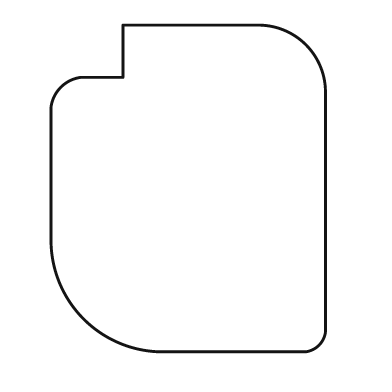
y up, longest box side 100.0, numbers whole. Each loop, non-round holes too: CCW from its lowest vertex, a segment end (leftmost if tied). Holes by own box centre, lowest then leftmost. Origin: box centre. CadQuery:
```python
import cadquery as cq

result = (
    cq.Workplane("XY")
    .moveTo(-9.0, -50.0)
    .lineTo(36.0, -50.0)
    .threePointArc((40.0, -48.0), (42.0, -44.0))
    .lineTo(42.0, 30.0)
    .threePointArc((36.0, 44.0), (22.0, 50.0))
    .lineTo(-20.0, 50.0)
    .lineTo(-20.0, 34.0)
    .lineTo(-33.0, 34.0)
    .threePointArc((-39.0, 31.0), (-42.0, 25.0))
    .lineTo(-42.0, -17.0)
    .threePointArc((-32.0, -40.0), (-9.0, -50.0))
    .close()
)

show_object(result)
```